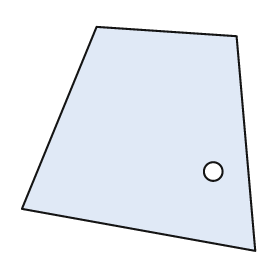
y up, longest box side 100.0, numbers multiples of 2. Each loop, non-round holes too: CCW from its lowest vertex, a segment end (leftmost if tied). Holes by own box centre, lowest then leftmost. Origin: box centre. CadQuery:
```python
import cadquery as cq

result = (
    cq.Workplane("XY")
    .moveTo(50.0, -48.0)
    .lineTo(42.0, 44.0)
    .lineTo(-18.0, 48.0)
    .lineTo(-50.0, -30.0)
    .close()
    .moveTo(32.0, -14.0)
    .circle(4.0)
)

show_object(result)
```